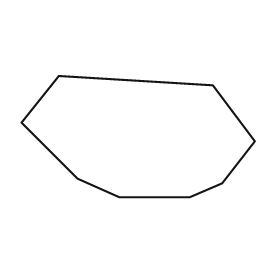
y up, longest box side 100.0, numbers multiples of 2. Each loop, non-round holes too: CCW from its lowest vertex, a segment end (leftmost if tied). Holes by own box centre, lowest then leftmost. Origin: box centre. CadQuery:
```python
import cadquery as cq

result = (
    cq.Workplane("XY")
    .moveTo(-8.0, -26.0)
    .lineTo(22.0, -26.0)
    .lineTo(36.0, -20.0)
    .lineTo(50.0, -2.0)
    .lineTo(32.0, 22.0)
    .lineTo(-34.0, 26.0)
    .lineTo(-50.0, 6.0)
    .lineTo(-26.0, -18.0)
    .close()
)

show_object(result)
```